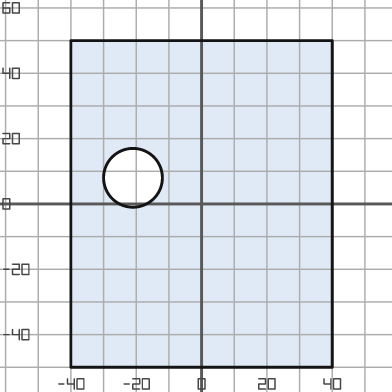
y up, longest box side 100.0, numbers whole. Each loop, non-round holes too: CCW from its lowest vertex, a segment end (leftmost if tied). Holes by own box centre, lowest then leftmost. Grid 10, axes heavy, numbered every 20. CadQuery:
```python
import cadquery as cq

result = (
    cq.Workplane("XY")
    .moveTo(-40.0, -50.0)
    .lineTo(40.0, -50.0)
    .lineTo(40.0, 50.0)
    .lineTo(-40.0, 50.0)
    .close()
    .moveTo(-21.0, 8.0)
    .circle(9.0)
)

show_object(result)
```